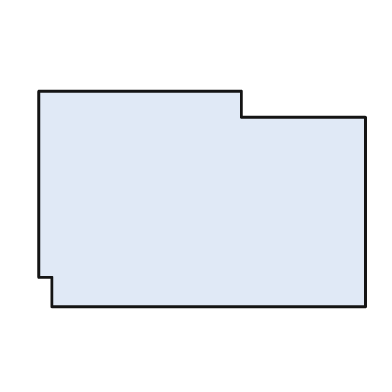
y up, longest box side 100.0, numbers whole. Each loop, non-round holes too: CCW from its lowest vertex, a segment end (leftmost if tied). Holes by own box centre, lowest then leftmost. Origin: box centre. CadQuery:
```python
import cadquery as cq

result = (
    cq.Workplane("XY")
    .moveTo(-46.0, -33.0)
    .lineTo(50.0, -33.0)
    .lineTo(50.0, 25.0)
    .lineTo(12.0, 25.0)
    .lineTo(12.0, 33.0)
    .lineTo(-50.0, 33.0)
    .lineTo(-50.0, -24.0)
    .lineTo(-46.0, -24.0)
    .close()
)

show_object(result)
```